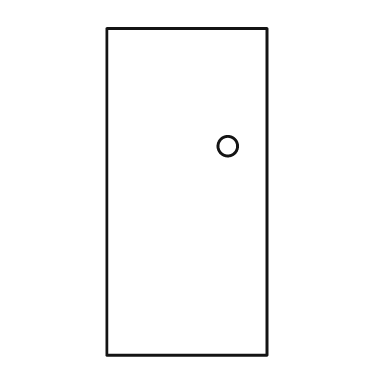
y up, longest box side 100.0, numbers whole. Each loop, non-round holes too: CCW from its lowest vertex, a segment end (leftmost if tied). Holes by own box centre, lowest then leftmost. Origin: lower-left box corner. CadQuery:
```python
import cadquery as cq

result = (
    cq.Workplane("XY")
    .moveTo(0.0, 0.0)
    .lineTo(49.0, 0.0)
    .lineTo(49.0, 100.0)
    .lineTo(0.0, 100.0)
    .close()
    .moveTo(37.0, 64.0)
    .circle(3.0)
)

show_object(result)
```